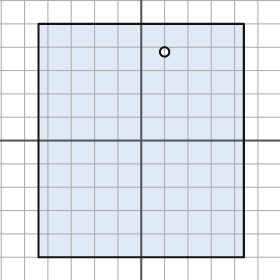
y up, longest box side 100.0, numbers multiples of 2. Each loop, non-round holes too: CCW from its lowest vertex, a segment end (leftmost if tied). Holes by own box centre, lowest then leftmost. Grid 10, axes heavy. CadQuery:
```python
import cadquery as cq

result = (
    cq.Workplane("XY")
    .moveTo(-44.0, -50.0)
    .lineTo(44.0, -50.0)
    .lineTo(44.0, 50.0)
    .lineTo(-44.0, 50.0)
    .close()
    .moveTo(10.0, 38.0)
    .circle(2.0)
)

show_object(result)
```